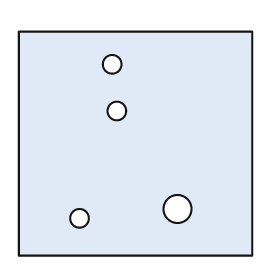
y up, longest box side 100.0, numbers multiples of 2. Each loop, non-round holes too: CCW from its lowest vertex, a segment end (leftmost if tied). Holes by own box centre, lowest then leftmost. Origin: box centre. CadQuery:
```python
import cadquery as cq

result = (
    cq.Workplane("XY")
    .moveTo(-50.0, -48.0)
    .lineTo(50.0, -48.0)
    .lineTo(50.0, 48.0)
    .lineTo(-50.0, 48.0)
    .close()
    .moveTo(-24.0, -32.0)
    .circle(4.0)
    .moveTo(18.0, -28.0)
    .circle(6.0)
    .moveTo(-8.0, 14.0)
    .circle(4.0)
    .moveTo(-10.0, 34.0)
    .circle(4.0)
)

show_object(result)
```